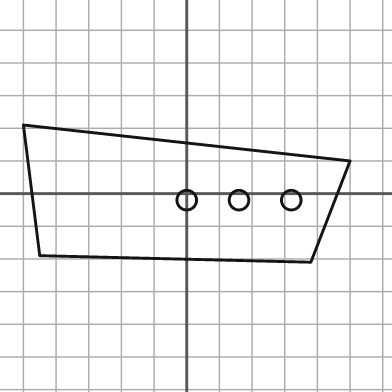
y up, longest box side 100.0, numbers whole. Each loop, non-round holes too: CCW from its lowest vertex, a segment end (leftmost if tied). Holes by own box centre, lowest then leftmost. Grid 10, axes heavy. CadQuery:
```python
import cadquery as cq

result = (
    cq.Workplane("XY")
    .moveTo(38.0, -21.0)
    .lineTo(50.0, 10.0)
    .lineTo(-50.0, 21.0)
    .lineTo(-45.0, -19.0)
    .close()
    .moveTo(0.0, -2.0)
    .circle(3.0)
    .moveTo(16.0, -2.0)
    .circle(3.0)
    .moveTo(32.0, -2.0)
    .circle(3.0)
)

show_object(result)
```